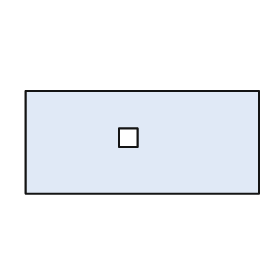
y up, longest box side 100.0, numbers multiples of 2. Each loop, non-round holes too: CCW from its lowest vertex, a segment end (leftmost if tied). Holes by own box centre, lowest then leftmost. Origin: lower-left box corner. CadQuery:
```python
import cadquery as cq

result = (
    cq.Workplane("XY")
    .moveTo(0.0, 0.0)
    .lineTo(100.0, 0.0)
    .lineTo(100.0, 44.0)
    .lineTo(0.0, 44.0)
    .close()
    .moveTo(40.0, 20.0)
    .lineTo(48.0, 20.0)
    .lineTo(48.0, 28.0)
    .lineTo(40.0, 28.0)
    .close()
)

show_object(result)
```